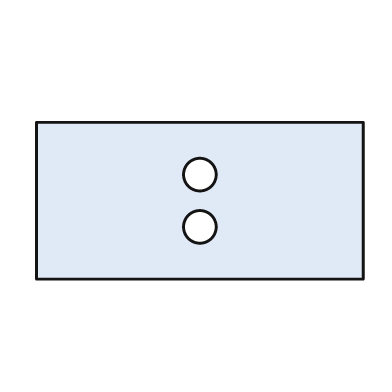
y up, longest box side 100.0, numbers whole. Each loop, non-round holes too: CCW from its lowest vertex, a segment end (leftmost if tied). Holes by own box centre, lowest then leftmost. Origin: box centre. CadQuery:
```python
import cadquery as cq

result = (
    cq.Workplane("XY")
    .moveTo(-50.0, -24.0)
    .lineTo(50.0, -24.0)
    .lineTo(50.0, 24.0)
    .lineTo(-50.0, 24.0)
    .close()
    .moveTo(0.0, -8.0)
    .circle(5.0)
    .moveTo(0.0, 8.0)
    .circle(5.0)
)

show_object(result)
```